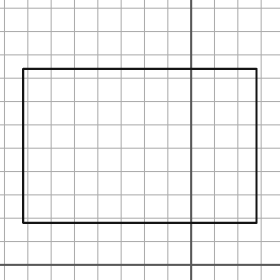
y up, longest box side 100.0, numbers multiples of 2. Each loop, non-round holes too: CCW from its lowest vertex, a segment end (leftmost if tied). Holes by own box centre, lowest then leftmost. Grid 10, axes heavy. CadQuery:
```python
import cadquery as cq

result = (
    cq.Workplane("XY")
    .moveTo(-72.0, 18.0)
    .lineTo(28.0, 18.0)
    .lineTo(28.0, 84.0)
    .lineTo(-72.0, 84.0)
    .close()
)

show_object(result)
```